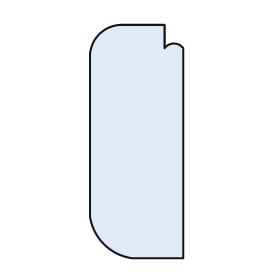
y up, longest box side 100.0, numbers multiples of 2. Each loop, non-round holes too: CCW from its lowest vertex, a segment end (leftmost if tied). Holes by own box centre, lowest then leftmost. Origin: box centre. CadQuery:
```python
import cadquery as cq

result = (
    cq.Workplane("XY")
    .moveTo(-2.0, -50.0)
    .lineTo(20.0, -50.0)
    .lineTo(20.0, 40.0)
    .threePointArc((16.0, 42.0), (12.0, 40.0))
    .lineTo(12.0, 50.0)
    .lineTo(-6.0, 50.0)
    .threePointArc((-16.0, 46.0), (-20.0, 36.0))
    .lineTo(-20.0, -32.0)
    .threePointArc((-14.0, -44.0), (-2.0, -50.0))
    .close()
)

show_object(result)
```